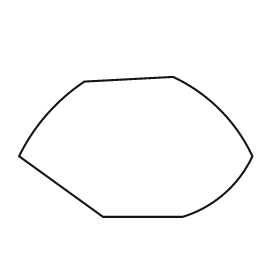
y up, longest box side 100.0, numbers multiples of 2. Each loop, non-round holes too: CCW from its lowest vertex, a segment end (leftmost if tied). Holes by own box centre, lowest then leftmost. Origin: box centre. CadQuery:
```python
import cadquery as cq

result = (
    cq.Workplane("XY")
    .moveTo(-14.0, -30.0)
    .lineTo(20.0, -30.0)
    .threePointArc((38.0, -20.0), (50.0, -4.0))
    .threePointArc((36.0, 16.0), (16.0, 30.0))
    .lineTo(-22.0, 28.0)
    .threePointArc((-38.0, 14.0), (-50.0, -4.0))
    .close()
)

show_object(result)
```